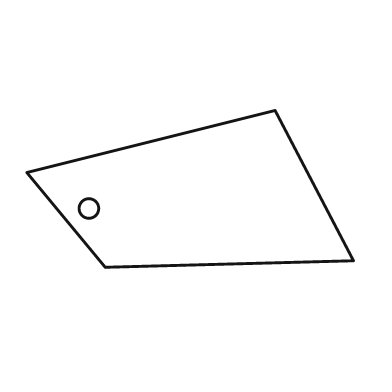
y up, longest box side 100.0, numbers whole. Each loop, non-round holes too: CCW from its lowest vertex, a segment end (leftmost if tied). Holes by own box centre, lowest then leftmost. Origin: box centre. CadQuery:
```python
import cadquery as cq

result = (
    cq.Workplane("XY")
    .moveTo(-26.0, -24.0)
    .lineTo(50.0, -22.0)
    .lineTo(26.0, 24.0)
    .lineTo(-50.0, 5.0)
    .close()
    .moveTo(-31.0, -6.0)
    .circle(3.0)
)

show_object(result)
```